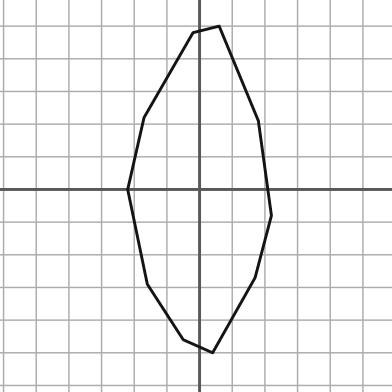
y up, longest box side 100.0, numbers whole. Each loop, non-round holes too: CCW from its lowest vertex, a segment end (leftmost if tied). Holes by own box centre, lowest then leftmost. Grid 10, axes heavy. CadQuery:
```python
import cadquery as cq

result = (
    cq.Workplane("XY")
    .moveTo(4.0, -50.0)
    .lineTo(17.0, -27.0)
    .lineTo(22.0, -8.0)
    .lineTo(18.0, 21.0)
    .lineTo(6.0, 50.0)
    .lineTo(-2.0, 48.0)
    .lineTo(-17.0, 22.0)
    .lineTo(-22.0, 0.0)
    .lineTo(-16.0, -29.0)
    .lineTo(-5.0, -46.0)
    .close()
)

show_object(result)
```